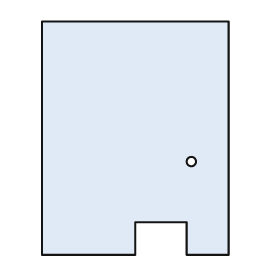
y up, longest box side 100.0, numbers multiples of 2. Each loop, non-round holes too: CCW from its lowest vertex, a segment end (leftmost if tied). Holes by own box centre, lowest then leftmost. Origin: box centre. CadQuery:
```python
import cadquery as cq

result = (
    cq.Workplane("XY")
    .moveTo(-40.0, -50.0)
    .lineTo(0.0, -50.0)
    .lineTo(0.0, -36.0)
    .lineTo(22.0, -36.0)
    .lineTo(22.0, -50.0)
    .lineTo(40.0, -50.0)
    .lineTo(40.0, 50.0)
    .lineTo(-40.0, 50.0)
    .close()
    .moveTo(24.0, -10.0)
    .circle(2.0)
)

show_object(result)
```